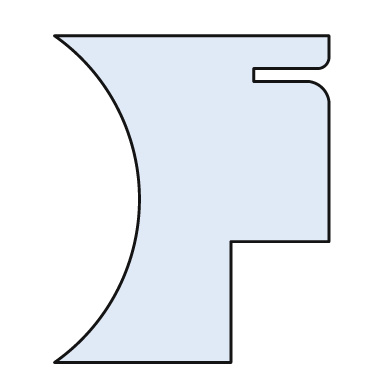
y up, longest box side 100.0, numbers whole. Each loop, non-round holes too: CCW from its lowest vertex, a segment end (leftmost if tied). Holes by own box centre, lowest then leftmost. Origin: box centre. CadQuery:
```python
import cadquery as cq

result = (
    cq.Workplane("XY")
    .moveTo(-42.0, -50.0)
    .lineTo(12.0, -50.0)
    .lineTo(12.0, -13.0)
    .lineTo(42.0, -13.0)
    .lineTo(42.0, 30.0)
    .threePointArc((40.0, 34.0), (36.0, 36.0))
    .lineTo(19.0, 36.0)
    .lineTo(19.0, 40.0)
    .lineTo(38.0, 40.0)
    .threePointArc((41.0, 41.0), (42.0, 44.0))
    .lineTo(42.0, 50.0)
    .lineTo(-42.0, 50.0)
    .threePointArc((-16.0, 0.0), (-42.0, -50.0))
    .close()
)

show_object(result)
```